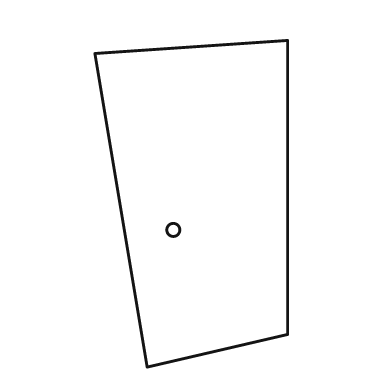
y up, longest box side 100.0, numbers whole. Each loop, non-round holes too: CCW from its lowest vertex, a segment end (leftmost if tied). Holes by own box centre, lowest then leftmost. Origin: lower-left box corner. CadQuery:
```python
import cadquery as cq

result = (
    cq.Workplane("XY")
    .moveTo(16.0, 0.0)
    .lineTo(59.0, 10.0)
    .lineTo(59.0, 100.0)
    .lineTo(0.0, 96.0)
    .close()
    .moveTo(24.0, 42.0)
    .circle(2.0)
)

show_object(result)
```